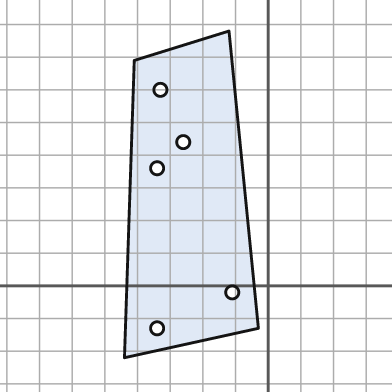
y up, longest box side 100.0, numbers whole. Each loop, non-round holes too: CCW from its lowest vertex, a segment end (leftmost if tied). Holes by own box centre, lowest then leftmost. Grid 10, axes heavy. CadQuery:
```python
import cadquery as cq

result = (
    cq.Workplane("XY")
    .moveTo(-44.0, -22.0)
    .lineTo(-3.0, -13.0)
    .lineTo(-12.0, 78.0)
    .lineTo(-41.0, 69.0)
    .close()
    .moveTo(-34.0, -13.0)
    .circle(2.0)
    .moveTo(-11.0, -2.0)
    .circle(2.0)
    .moveTo(-34.0, 36.0)
    .circle(2.0)
    .moveTo(-26.0, 44.0)
    .circle(2.0)
    .moveTo(-33.0, 60.0)
    .circle(2.0)
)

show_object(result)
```